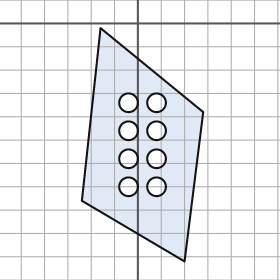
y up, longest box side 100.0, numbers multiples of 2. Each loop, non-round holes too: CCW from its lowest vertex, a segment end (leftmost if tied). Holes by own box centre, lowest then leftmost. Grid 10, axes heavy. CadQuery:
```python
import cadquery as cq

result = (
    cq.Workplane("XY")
    .moveTo(20.0, -102.0)
    .lineTo(28.0, -38.0)
    .lineTo(-16.0, -2.0)
    .lineTo(-24.0, -76.0)
    .close()
    .moveTo(-4.0, -70.0)
    .circle(4.0)
    .moveTo(8.0, -70.0)
    .circle(4.0)
    .moveTo(-4.0, -58.0)
    .circle(4.0)
    .moveTo(8.0, -58.0)
    .circle(4.0)
    .moveTo(-4.0, -46.0)
    .circle(4.0)
    .moveTo(8.0, -46.0)
    .circle(4.0)
    .moveTo(-4.0, -34.0)
    .circle(4.0)
    .moveTo(8.0, -34.0)
    .circle(4.0)
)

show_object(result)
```